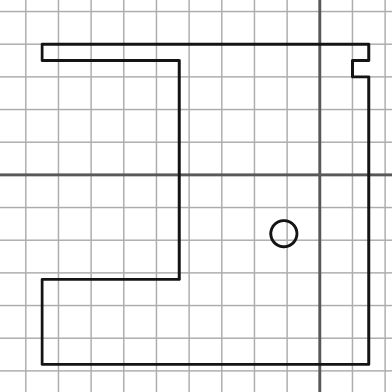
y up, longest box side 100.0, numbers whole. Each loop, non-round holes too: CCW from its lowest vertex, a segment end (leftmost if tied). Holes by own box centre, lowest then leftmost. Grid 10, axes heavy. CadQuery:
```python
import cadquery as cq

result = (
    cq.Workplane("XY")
    .moveTo(-85.0, -58.0)
    .lineTo(15.0, -58.0)
    .lineTo(15.0, 30.0)
    .lineTo(10.0, 30.0)
    .lineTo(10.0, 35.0)
    .lineTo(15.0, 35.0)
    .lineTo(15.0, 40.0)
    .lineTo(-85.0, 40.0)
    .lineTo(-85.0, 35.0)
    .lineTo(-43.0, 35.0)
    .lineTo(-43.0, -32.0)
    .lineTo(-85.0, -32.0)
    .close()
    .moveTo(-11.0, -18.0)
    .circle(4.0)
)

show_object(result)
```